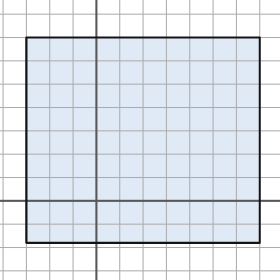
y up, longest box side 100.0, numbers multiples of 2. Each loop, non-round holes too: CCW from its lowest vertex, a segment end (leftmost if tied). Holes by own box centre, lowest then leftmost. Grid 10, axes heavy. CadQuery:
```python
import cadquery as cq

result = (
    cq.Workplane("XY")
    .moveTo(-30.0, -18.0)
    .lineTo(70.0, -18.0)
    .lineTo(70.0, 70.0)
    .lineTo(-30.0, 70.0)
    .close()
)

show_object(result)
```